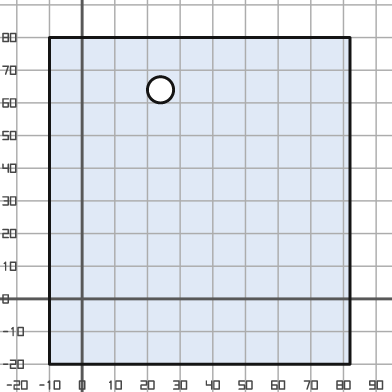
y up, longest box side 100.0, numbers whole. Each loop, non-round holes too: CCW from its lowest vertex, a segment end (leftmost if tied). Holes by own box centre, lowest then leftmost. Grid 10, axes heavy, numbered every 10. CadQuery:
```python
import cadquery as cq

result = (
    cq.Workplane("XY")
    .moveTo(-10.0, -20.0)
    .lineTo(82.0, -20.0)
    .lineTo(82.0, 80.0)
    .lineTo(-10.0, 80.0)
    .close()
    .moveTo(24.0, 64.0)
    .circle(4.0)
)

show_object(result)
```